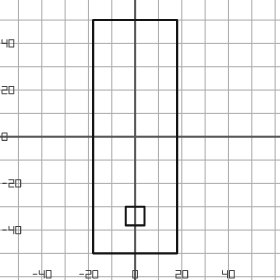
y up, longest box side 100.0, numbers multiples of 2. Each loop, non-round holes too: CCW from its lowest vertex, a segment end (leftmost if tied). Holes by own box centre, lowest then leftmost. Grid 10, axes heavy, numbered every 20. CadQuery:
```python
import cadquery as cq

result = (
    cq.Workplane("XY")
    .moveTo(-18.0, -50.0)
    .lineTo(18.0, -50.0)
    .lineTo(18.0, 50.0)
    .lineTo(-18.0, 50.0)
    .close()
    .moveTo(-4.0, -38.0)
    .lineTo(4.0, -38.0)
    .lineTo(4.0, -30.0)
    .lineTo(-4.0, -30.0)
    .close()
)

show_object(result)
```